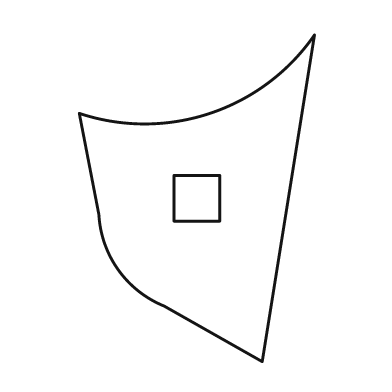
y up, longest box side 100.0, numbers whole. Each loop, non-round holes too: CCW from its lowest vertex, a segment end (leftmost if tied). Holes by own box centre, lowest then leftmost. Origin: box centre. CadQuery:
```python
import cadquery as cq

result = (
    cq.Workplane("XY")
    .moveTo(20.0, -50.0)
    .lineTo(36.0, 50.0)
    .threePointArc((4.0, 26.0), (-36.0, 26.0))
    .lineTo(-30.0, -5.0)
    .threePointArc((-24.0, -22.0), (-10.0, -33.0))
    .close()
    .moveTo(-7.0, -7.0)
    .lineTo(7.0, -7.0)
    .lineTo(7.0, 7.0)
    .lineTo(-7.0, 7.0)
    .close()
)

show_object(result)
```